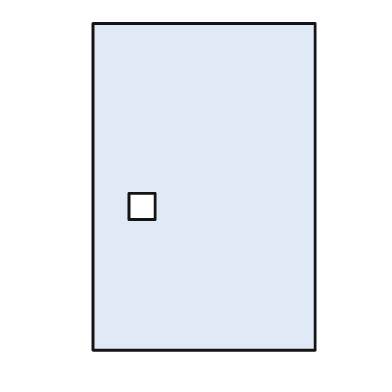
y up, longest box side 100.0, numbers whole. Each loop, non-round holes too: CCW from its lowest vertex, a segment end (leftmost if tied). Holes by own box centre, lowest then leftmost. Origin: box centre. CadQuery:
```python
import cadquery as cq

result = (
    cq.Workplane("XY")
    .moveTo(-34.0, -50.0)
    .lineTo(34.0, -50.0)
    .lineTo(34.0, 50.0)
    .lineTo(-34.0, 50.0)
    .close()
    .moveTo(-23.0, -10.0)
    .lineTo(-15.0, -10.0)
    .lineTo(-15.0, -2.0)
    .lineTo(-23.0, -2.0)
    .close()
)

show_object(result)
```